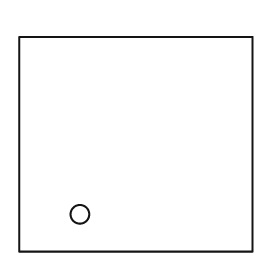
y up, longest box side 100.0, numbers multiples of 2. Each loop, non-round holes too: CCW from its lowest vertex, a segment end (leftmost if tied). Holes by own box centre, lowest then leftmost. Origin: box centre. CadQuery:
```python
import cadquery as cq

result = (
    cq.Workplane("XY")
    .moveTo(-50.0, -46.0)
    .lineTo(50.0, -46.0)
    .lineTo(50.0, 46.0)
    .lineTo(-50.0, 46.0)
    .close()
    .moveTo(-24.0, -30.0)
    .circle(4.0)
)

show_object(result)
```